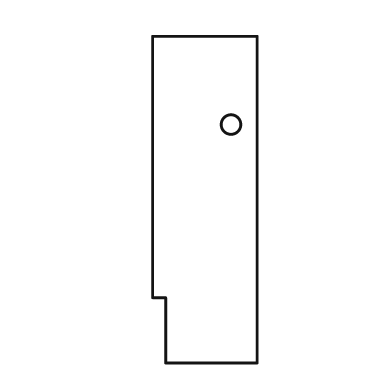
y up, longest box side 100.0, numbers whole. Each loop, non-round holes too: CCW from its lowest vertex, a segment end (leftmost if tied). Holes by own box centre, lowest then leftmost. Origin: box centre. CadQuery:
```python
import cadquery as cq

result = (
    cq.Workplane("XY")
    .moveTo(-12.0, -50.0)
    .lineTo(16.0, -50.0)
    .lineTo(16.0, 50.0)
    .lineTo(-16.0, 50.0)
    .lineTo(-16.0, -30.0)
    .lineTo(-12.0, -30.0)
    .close()
    .moveTo(8.0, 23.0)
    .circle(3.0)
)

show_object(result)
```